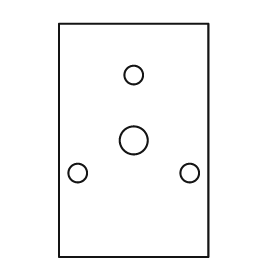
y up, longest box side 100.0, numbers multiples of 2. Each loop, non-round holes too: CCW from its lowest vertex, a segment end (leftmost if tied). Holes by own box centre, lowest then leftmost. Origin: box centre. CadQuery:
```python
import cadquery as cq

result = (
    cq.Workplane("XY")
    .moveTo(-32.0, -50.0)
    .lineTo(32.0, -50.0)
    .lineTo(32.0, 50.0)
    .lineTo(-32.0, 50.0)
    .close()
    .moveTo(-24.0, -14.0)
    .circle(4.0)
    .moveTo(24.0, -14.0)
    .circle(4.0)
    .moveTo(0.0, 0.0)
    .circle(6.0)
    .moveTo(0.0, 28.0)
    .circle(4.0)
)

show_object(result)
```